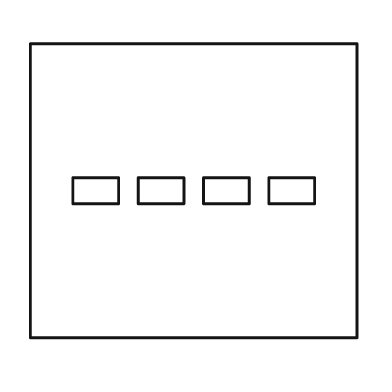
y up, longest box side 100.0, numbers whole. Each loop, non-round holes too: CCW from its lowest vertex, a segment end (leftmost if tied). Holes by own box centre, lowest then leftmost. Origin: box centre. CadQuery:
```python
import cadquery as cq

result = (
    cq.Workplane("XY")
    .moveTo(-50.0, -45.0)
    .lineTo(50.0, -45.0)
    .lineTo(50.0, 45.0)
    .lineTo(-50.0, 45.0)
    .close()
    .moveTo(-37.0, -4.0)
    .lineTo(-23.0, -4.0)
    .lineTo(-23.0, 4.0)
    .lineTo(-37.0, 4.0)
    .close()
    .moveTo(-17.0, -4.0)
    .lineTo(-3.0, -4.0)
    .lineTo(-3.0, 4.0)
    .lineTo(-17.0, 4.0)
    .close()
    .moveTo(3.0, -4.0)
    .lineTo(17.0, -4.0)
    .lineTo(17.0, 4.0)
    .lineTo(3.0, 4.0)
    .close()
    .moveTo(23.0, -4.0)
    .lineTo(37.0, -4.0)
    .lineTo(37.0, 4.0)
    .lineTo(23.0, 4.0)
    .close()
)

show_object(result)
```